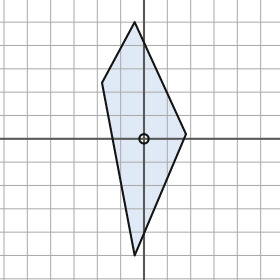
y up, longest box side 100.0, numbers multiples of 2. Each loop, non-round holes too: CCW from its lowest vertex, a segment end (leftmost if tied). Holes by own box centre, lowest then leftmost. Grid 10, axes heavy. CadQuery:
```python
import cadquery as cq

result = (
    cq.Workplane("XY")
    .moveTo(-4.0, -50.0)
    .lineTo(18.0, 2.0)
    .lineTo(-4.0, 50.0)
    .lineTo(-18.0, 24.0)
    .close()
    .moveTo(0.0, 0.0)
    .circle(2.0)
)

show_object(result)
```